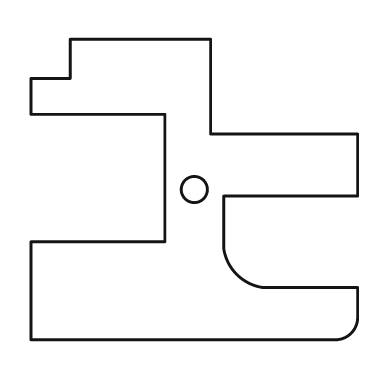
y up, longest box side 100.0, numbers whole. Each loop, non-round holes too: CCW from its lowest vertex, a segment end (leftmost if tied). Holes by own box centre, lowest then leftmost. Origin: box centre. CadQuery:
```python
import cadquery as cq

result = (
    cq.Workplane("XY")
    .moveTo(-50.0, -46.0)
    .lineTo(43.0, -46.0)
    .threePointArc((48.0, -44.0), (50.0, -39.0))
    .lineTo(50.0, -30.0)
    .lineTo(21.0, -30.0)
    .threePointArc((13.0, -26.0), (9.0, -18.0))
    .lineTo(9.0, -2.0)
    .lineTo(50.0, -2.0)
    .lineTo(50.0, 17.0)
    .lineTo(5.0, 17.0)
    .lineTo(5.0, 46.0)
    .lineTo(-38.0, 46.0)
    .lineTo(-38.0, 34.0)
    .lineTo(-50.0, 34.0)
    .lineTo(-50.0, 23.0)
    .lineTo(-9.0, 23.0)
    .lineTo(-9.0, -16.0)
    .lineTo(-50.0, -16.0)
    .close()
    .moveTo(0.0, 0.0)
    .circle(4.0)
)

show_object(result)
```